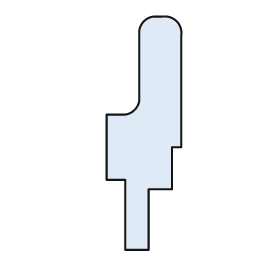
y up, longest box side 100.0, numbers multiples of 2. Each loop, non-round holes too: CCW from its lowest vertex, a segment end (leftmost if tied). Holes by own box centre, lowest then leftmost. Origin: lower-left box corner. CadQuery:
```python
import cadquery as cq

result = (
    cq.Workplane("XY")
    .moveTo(8.0, 0.0)
    .lineTo(18.0, 0.0)
    .lineTo(18.0, 26.0)
    .lineTo(28.0, 26.0)
    .lineTo(28.0, 44.0)
    .lineTo(32.0, 44.0)
    .lineTo(32.0, 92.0)
    .threePointArc((30.0, 98.0), (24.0, 100.0))
    .lineTo(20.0, 100.0)
    .threePointArc((16.0, 98.0), (14.0, 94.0))
    .lineTo(14.0, 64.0)
    .threePointArc((12.0, 60.0), (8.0, 58.0))
    .lineTo(0.0, 58.0)
    .lineTo(0.0, 30.0)
    .lineTo(8.0, 30.0)
    .close()
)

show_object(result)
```